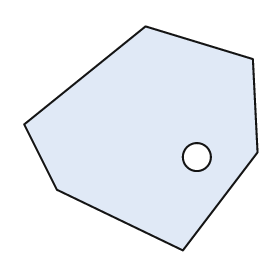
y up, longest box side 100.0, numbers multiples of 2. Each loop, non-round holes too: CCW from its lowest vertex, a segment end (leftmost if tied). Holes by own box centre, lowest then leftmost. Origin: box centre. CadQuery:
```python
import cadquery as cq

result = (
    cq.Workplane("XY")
    .moveTo(18.0, -48.0)
    .lineTo(50.0, -6.0)
    .lineTo(48.0, 34.0)
    .lineTo(2.0, 48.0)
    .lineTo(-50.0, 6.0)
    .lineTo(-36.0, -22.0)
    .close()
    .moveTo(24.0, -8.0)
    .circle(6.0)
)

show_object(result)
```